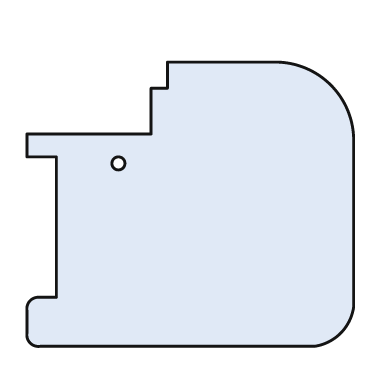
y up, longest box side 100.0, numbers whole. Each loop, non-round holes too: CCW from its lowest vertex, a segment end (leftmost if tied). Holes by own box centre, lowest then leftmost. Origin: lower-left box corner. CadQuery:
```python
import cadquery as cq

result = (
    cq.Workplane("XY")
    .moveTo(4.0, 0.0)
    .lineTo(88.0, 0.0)
    .threePointArc((96.0, 4.0), (100.0, 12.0))
    .lineTo(100.0, 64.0)
    .threePointArc((93.0, 80.0), (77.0, 87.0))
    .lineTo(43.0, 87.0)
    .lineTo(43.0, 79.0)
    .lineTo(38.0, 79.0)
    .lineTo(38.0, 65.0)
    .lineTo(0.0, 65.0)
    .lineTo(0.0, 58.0)
    .lineTo(9.0, 58.0)
    .lineTo(9.0, 15.0)
    .lineTo(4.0, 15.0)
    .threePointArc((1.0, 14.0), (0.0, 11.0))
    .lineTo(0.0, 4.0)
    .threePointArc((1.0, 1.0), (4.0, 0.0))
    .close()
    .moveTo(28.0, 56.0)
    .circle(2.0)
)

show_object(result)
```